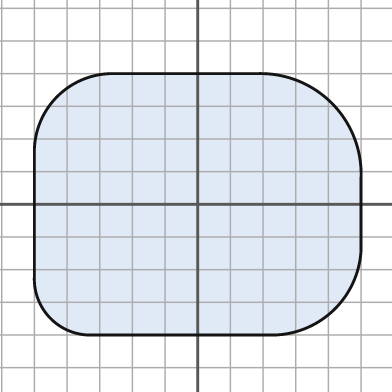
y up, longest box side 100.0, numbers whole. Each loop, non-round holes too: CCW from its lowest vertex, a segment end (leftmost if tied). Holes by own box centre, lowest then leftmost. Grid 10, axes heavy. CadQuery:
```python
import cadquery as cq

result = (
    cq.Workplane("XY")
    .moveTo(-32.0, -40.0)
    .lineTo(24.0, -40.0)
    .threePointArc((42.0, -32.0), (50.0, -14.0))
    .lineTo(50.0, 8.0)
    .threePointArc((41.0, 31.0), (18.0, 40.0))
    .lineTo(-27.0, 40.0)
    .threePointArc((-43.0, 33.0), (-50.0, 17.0))
    .lineTo(-50.0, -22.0)
    .threePointArc((-45.0, -35.0), (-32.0, -40.0))
    .close()
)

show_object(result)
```